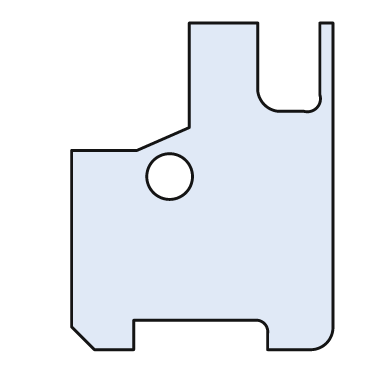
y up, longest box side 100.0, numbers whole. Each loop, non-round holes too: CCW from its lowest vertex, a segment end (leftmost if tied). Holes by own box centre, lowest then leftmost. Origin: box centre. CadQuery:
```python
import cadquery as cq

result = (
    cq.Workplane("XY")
    .moveTo(-33.0, -50.0)
    .lineTo(-21.0, -50.0)
    .lineTo(-21.0, -41.0)
    .lineTo(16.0, -41.0)
    .threePointArc((19.0, -42.0), (20.0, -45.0))
    .lineTo(20.0, -50.0)
    .lineTo(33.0, -50.0)
    .threePointArc((38.0, -48.0), (40.0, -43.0))
    .lineTo(40.0, 50.0)
    .lineTo(36.0, 50.0)
    .lineTo(36.0, 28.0)
    .threePointArc((35.0, 24.0), (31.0, 23.0))
    .lineTo(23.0, 23.0)
    .threePointArc((19.0, 25.0), (17.0, 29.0))
    .lineTo(17.0, 50.0)
    .lineTo(-4.0, 50.0)
    .lineTo(-4.0, 18.0)
    .lineTo(-20.0, 11.0)
    .lineTo(-40.0, 11.0)
    .lineTo(-40.0, -43.0)
    .close()
    .moveTo(-10.0, 3.0)
    .circle(7.0)
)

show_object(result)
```